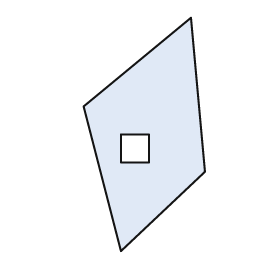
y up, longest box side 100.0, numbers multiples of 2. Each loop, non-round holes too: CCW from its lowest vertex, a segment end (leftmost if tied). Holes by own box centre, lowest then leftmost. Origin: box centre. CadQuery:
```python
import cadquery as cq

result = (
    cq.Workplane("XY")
    .moveTo(-10.0, -50.0)
    .lineTo(26.0, -16.0)
    .lineTo(20.0, 50.0)
    .lineTo(-26.0, 12.0)
    .close()
    .moveTo(-10.0, -12.0)
    .lineTo(2.0, -12.0)
    .lineTo(2.0, 0.0)
    .lineTo(-10.0, 0.0)
    .close()
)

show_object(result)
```